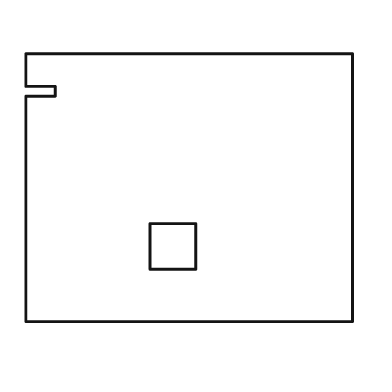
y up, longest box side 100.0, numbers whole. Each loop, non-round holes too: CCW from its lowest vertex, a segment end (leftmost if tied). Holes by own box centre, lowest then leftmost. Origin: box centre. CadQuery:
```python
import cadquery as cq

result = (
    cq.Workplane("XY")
    .moveTo(-50.0, -41.0)
    .lineTo(50.0, -41.0)
    .lineTo(50.0, 41.0)
    .lineTo(-50.0, 41.0)
    .lineTo(-50.0, 31.0)
    .lineTo(-41.0, 31.0)
    .lineTo(-41.0, 28.0)
    .lineTo(-50.0, 28.0)
    .close()
    .moveTo(-12.0, -25.0)
    .lineTo(2.0, -25.0)
    .lineTo(2.0, -11.0)
    .lineTo(-12.0, -11.0)
    .close()
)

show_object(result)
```